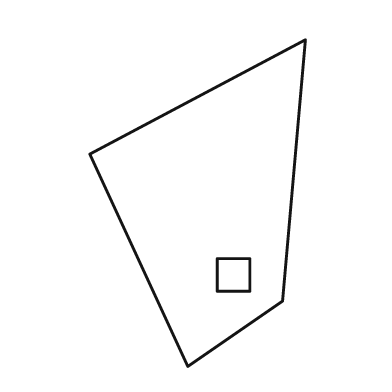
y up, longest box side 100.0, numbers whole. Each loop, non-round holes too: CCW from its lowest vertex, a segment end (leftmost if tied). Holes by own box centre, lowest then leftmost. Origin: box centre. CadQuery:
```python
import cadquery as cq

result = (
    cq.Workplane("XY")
    .moveTo(-3.0, -50.0)
    .lineTo(26.0, -30.0)
    .lineTo(33.0, 50.0)
    .lineTo(-33.0, 15.0)
    .close()
    .moveTo(6.0, -27.0)
    .lineTo(16.0, -27.0)
    .lineTo(16.0, -17.0)
    .lineTo(6.0, -17.0)
    .close()
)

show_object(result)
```